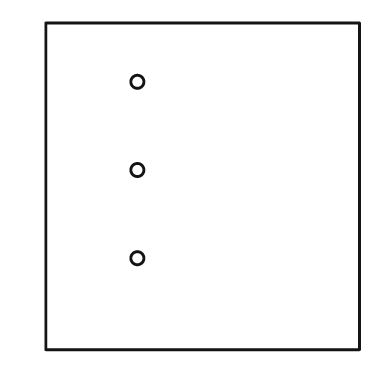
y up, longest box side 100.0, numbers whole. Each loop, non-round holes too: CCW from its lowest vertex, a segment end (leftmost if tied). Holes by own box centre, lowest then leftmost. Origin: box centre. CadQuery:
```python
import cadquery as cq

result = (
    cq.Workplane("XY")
    .moveTo(-48.0, -50.0)
    .lineTo(48.0, -50.0)
    .lineTo(48.0, 50.0)
    .lineTo(-48.0, 50.0)
    .close()
    .moveTo(-20.0, -22.0)
    .circle(2.0)
    .moveTo(-20.0, 5.0)
    .circle(2.0)
    .moveTo(-20.0, 32.0)
    .circle(2.0)
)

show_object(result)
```